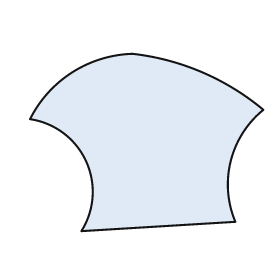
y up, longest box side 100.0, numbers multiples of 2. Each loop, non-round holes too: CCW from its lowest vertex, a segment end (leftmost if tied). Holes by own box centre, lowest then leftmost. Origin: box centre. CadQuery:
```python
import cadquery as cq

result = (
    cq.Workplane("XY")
    .moveTo(-28.0, -38.0)
    .lineTo(38.0, -34.0)
    .threePointArc((36.0, -8.0), (50.0, 14.0))
    .threePointArc((24.0, 30.0), (-6.0, 38.0))
    .threePointArc((-32.0, 30.0), (-50.0, 10.0))
    .threePointArc((-26.0, -8.0), (-28.0, -38.0))
    .close()
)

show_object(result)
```